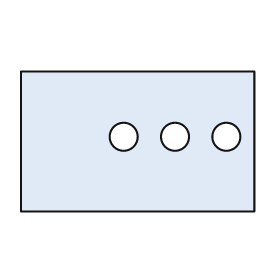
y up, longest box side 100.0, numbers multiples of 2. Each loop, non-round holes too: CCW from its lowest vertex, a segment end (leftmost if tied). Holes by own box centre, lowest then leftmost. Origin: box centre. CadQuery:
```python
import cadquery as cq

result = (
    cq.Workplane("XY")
    .moveTo(-50.0, -30.0)
    .lineTo(50.0, -30.0)
    .lineTo(50.0, 30.0)
    .lineTo(-50.0, 30.0)
    .close()
    .moveTo(-6.0, 2.0)
    .circle(6.0)
    .moveTo(16.0, 2.0)
    .circle(6.0)
    .moveTo(38.0, 2.0)
    .circle(6.0)
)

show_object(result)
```